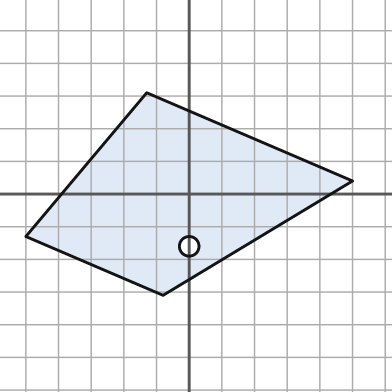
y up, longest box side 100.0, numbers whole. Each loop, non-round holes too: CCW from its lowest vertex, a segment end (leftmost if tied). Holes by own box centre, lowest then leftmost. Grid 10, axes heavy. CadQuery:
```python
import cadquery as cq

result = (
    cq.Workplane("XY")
    .moveTo(-8.0, -31.0)
    .lineTo(50.0, 4.0)
    .lineTo(-13.0, 31.0)
    .lineTo(-50.0, -13.0)
    .close()
    .moveTo(0.0, -16.0)
    .circle(3.0)
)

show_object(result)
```